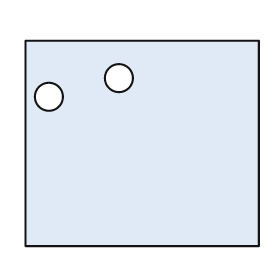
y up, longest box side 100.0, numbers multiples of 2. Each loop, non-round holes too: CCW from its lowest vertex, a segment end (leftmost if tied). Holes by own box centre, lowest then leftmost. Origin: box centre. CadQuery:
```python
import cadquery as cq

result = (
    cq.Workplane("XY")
    .moveTo(-50.0, -44.0)
    .lineTo(50.0, -44.0)
    .lineTo(50.0, 44.0)
    .lineTo(-50.0, 44.0)
    .close()
    .moveTo(-40.0, 20.0)
    .circle(6.0)
    .moveTo(-10.0, 28.0)
    .circle(6.0)
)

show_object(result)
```